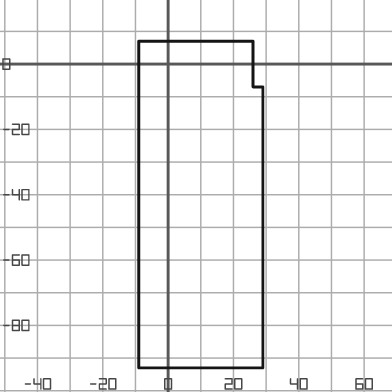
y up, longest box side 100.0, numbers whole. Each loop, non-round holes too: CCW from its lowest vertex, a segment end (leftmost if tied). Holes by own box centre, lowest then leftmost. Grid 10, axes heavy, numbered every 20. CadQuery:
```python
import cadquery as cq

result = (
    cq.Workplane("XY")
    .moveTo(-9.0, -93.0)
    .lineTo(29.0, -93.0)
    .lineTo(29.0, -7.0)
    .lineTo(26.0, -7.0)
    .lineTo(26.0, 7.0)
    .lineTo(-9.0, 7.0)
    .close()
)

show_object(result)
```